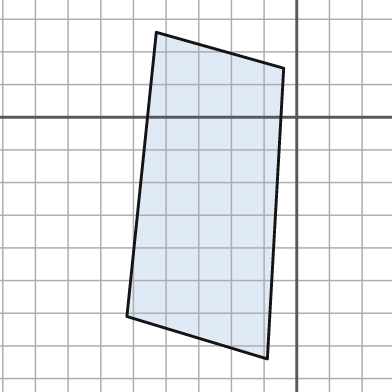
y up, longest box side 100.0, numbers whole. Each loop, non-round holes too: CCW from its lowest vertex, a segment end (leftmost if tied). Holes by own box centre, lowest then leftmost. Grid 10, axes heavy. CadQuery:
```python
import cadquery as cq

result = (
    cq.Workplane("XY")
    .moveTo(-9.0, -74.0)
    .lineTo(-4.0, 15.0)
    .lineTo(-43.0, 26.0)
    .lineTo(-52.0, -61.0)
    .close()
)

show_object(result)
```